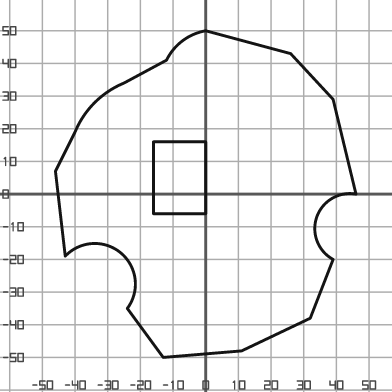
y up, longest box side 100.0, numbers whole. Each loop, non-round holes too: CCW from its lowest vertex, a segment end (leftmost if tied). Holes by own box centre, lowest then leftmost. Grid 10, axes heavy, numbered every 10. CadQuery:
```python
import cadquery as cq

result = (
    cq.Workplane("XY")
    .moveTo(-13.0, -50.0)
    .lineTo(11.0, -48.0)
    .lineTo(32.0, -38.0)
    .lineTo(39.0, -20.0)
    .threePointArc((34.0, -7.0), (46.0, 0.0))
    .lineTo(39.0, 29.0)
    .lineTo(26.0, 43.0)
    .lineTo(0.0, 50.0)
    .threePointArc((-7.0, 47.0), (-12.0, 41.0))
    .lineTo(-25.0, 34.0)
    .threePointArc((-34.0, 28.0), (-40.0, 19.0))
    .lineTo(-46.0, 7.0)
    .lineTo(-43.0, -19.0)
    .threePointArc((-26.0, -18.0), (-24.0, -35.0))
    .close()
    .moveTo(-16.0, -6.0)
    .lineTo(0.0, -6.0)
    .lineTo(0.0, 16.0)
    .lineTo(-16.0, 16.0)
    .close()
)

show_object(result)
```